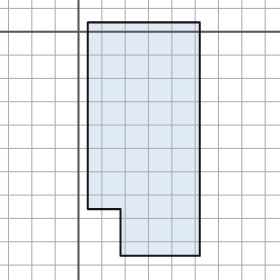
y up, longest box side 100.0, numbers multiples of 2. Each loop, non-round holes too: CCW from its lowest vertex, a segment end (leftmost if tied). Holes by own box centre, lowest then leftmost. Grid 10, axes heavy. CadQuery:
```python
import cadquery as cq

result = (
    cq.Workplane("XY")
    .moveTo(18.0, -96.0)
    .lineTo(52.0, -96.0)
    .lineTo(52.0, 4.0)
    .lineTo(4.0, 4.0)
    .lineTo(4.0, -76.0)
    .lineTo(18.0, -76.0)
    .close()
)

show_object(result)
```